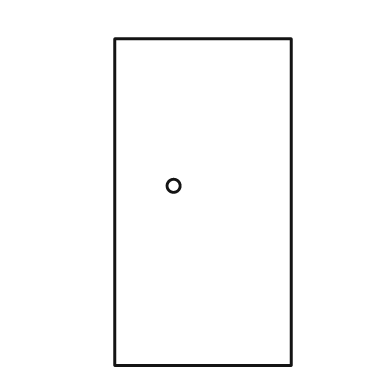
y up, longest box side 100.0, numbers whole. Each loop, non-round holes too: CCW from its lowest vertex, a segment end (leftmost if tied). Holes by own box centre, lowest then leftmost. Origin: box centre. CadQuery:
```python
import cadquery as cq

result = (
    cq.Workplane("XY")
    .moveTo(-27.0, -50.0)
    .lineTo(27.0, -50.0)
    .lineTo(27.0, 50.0)
    .lineTo(-27.0, 50.0)
    .close()
    .moveTo(-9.0, 5.0)
    .circle(2.0)
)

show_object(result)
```